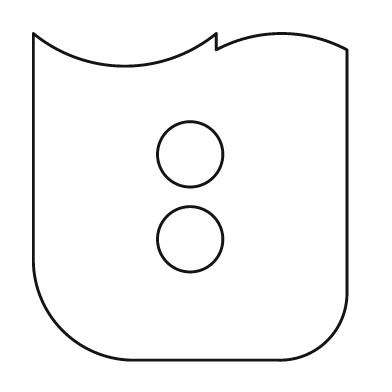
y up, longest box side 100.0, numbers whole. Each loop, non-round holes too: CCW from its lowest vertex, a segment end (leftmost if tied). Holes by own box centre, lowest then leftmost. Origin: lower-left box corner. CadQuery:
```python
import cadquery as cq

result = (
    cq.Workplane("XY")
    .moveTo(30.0, 0.0)
    .lineTo(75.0, 0.0)
    .threePointArc((90.0, 6.0), (96.0, 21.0))
    .lineTo(96.0, 95.0)
    .threePointArc((76.0, 100.0), (56.0, 95.0))
    .lineTo(56.0, 100.0)
    .threePointArc((28.0, 90.0), (0.0, 100.0))
    .lineTo(0.0, 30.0)
    .threePointArc((9.0, 9.0), (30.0, 0.0))
    .close()
    .moveTo(48.0, 37.0)
    .circle(10.0)
    .moveTo(48.0, 63.0)
    .circle(10.0)
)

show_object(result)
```